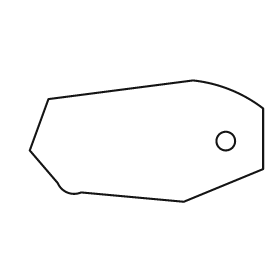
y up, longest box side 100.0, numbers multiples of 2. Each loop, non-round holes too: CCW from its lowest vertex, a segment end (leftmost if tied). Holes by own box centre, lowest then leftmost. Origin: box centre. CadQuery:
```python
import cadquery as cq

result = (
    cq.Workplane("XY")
    .moveTo(16.0, -26.0)
    .lineTo(50.0, -12.0)
    .lineTo(50.0, 14.0)
    .threePointArc((36.0, 22.0), (20.0, 26.0))
    .lineTo(-42.0, 18.0)
    .lineTo(-50.0, -4.0)
    .lineTo(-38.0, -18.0)
    .threePointArc((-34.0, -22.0), (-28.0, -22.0))
    .close()
    .moveTo(34.0, 0.0)
    .circle(4.0)
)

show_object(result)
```